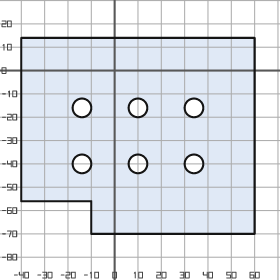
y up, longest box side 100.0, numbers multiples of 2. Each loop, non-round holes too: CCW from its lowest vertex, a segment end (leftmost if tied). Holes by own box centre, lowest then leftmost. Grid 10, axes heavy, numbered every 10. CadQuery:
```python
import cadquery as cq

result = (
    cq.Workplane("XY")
    .moveTo(-10.0, -70.0)
    .lineTo(60.0, -70.0)
    .lineTo(60.0, 14.0)
    .lineTo(-40.0, 14.0)
    .lineTo(-40.0, -56.0)
    .lineTo(-10.0, -56.0)
    .close()
    .moveTo(-14.0, -40.0)
    .circle(4.0)
    .moveTo(10.0, -40.0)
    .circle(4.0)
    .moveTo(34.0, -40.0)
    .circle(4.0)
    .moveTo(-14.0, -16.0)
    .circle(4.0)
    .moveTo(10.0, -16.0)
    .circle(4.0)
    .moveTo(34.0, -16.0)
    .circle(4.0)
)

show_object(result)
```